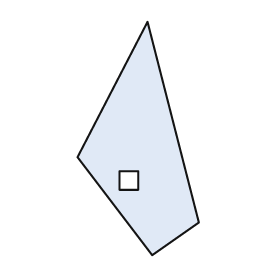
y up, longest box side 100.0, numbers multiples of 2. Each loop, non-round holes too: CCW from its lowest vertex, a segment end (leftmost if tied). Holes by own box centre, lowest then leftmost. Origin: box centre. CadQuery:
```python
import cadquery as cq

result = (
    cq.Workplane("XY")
    .moveTo(6.0, -50.0)
    .lineTo(26.0, -36.0)
    .lineTo(4.0, 50.0)
    .lineTo(-26.0, -8.0)
    .close()
    .moveTo(-8.0, -22.0)
    .lineTo(0.0, -22.0)
    .lineTo(0.0, -14.0)
    .lineTo(-8.0, -14.0)
    .close()
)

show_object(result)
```